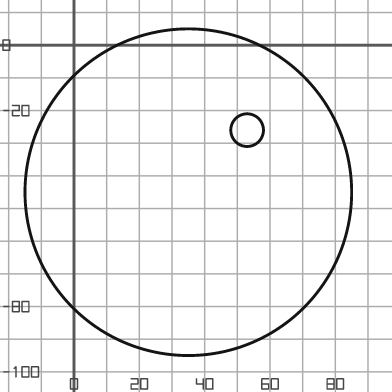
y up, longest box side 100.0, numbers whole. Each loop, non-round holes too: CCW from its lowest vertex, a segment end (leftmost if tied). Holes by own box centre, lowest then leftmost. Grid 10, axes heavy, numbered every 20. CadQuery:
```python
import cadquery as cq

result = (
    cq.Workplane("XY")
    .moveTo(35.0, -45.0)
    .circle(50.0)
    .moveTo(53.0, -26.0)
    .circle(5.0)
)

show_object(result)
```